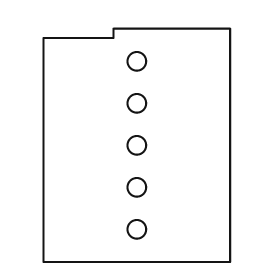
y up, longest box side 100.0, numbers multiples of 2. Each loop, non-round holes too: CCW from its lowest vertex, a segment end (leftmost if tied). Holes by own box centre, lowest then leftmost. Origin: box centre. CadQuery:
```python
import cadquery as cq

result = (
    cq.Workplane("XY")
    .moveTo(-40.0, -50.0)
    .lineTo(40.0, -50.0)
    .lineTo(40.0, 50.0)
    .lineTo(-10.0, 50.0)
    .lineTo(-10.0, 46.0)
    .lineTo(-40.0, 46.0)
    .close()
    .moveTo(0.0, -36.0)
    .circle(4.0)
    .moveTo(0.0, -18.0)
    .circle(4.0)
    .moveTo(0.0, 0.0)
    .circle(4.0)
    .moveTo(0.0, 18.0)
    .circle(4.0)
    .moveTo(0.0, 36.0)
    .circle(4.0)
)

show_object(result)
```